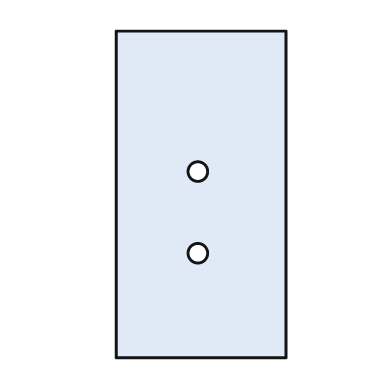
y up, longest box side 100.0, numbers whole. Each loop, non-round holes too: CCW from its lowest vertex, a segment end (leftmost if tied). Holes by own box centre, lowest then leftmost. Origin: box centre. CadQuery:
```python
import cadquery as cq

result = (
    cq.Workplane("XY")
    .moveTo(-26.0, -50.0)
    .lineTo(26.0, -50.0)
    .lineTo(26.0, 50.0)
    .lineTo(-26.0, 50.0)
    .close()
    .moveTo(-1.0, -18.0)
    .circle(3.0)
    .moveTo(-1.0, 7.0)
    .circle(3.0)
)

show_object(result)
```